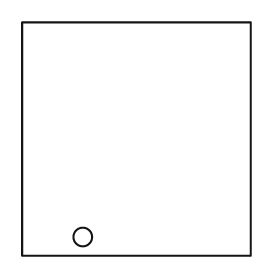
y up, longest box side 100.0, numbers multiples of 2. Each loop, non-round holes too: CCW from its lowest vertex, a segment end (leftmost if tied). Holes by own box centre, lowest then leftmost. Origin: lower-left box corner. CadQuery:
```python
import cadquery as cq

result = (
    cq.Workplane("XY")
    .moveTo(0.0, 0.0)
    .lineTo(98.0, 0.0)
    .lineTo(98.0, 100.0)
    .lineTo(0.0, 100.0)
    .close()
    .moveTo(26.0, 8.0)
    .circle(4.0)
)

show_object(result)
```